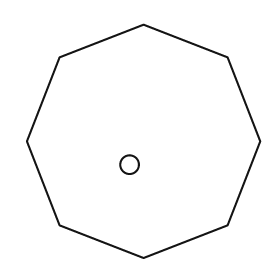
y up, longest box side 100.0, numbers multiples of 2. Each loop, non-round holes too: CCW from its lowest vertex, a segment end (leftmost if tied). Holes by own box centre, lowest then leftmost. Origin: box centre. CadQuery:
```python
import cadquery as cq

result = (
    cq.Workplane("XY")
    .moveTo(0.0, -50.0)
    .lineTo(36.0, -36.0)
    .lineTo(50.0, 0.0)
    .lineTo(36.0, 36.0)
    .lineTo(0.0, 50.0)
    .lineTo(-36.0, 36.0)
    .lineTo(-50.0, 0.0)
    .lineTo(-36.0, -36.0)
    .close()
    .moveTo(-6.0, -10.0)
    .circle(4.0)
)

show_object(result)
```